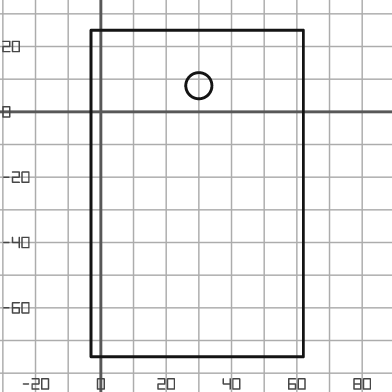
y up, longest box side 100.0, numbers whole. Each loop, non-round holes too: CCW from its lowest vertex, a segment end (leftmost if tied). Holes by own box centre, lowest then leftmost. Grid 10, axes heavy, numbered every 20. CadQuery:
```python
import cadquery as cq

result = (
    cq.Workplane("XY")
    .moveTo(-3.0, -75.0)
    .lineTo(62.0, -75.0)
    .lineTo(62.0, 25.0)
    .lineTo(-3.0, 25.0)
    .close()
    .moveTo(30.0, 8.0)
    .circle(4.0)
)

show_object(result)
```